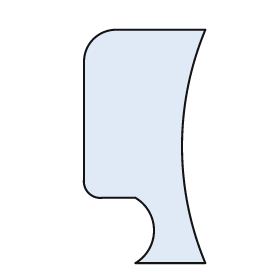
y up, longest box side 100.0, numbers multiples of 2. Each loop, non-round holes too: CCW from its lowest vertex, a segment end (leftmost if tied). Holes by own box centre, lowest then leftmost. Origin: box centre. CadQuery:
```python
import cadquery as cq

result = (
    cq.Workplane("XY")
    .moveTo(-4.0, -50.0)
    .lineTo(26.0, -50.0)
    .threePointArc((16.0, 0.0), (26.0, 50.0))
    .lineTo(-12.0, 50.0)
    .threePointArc((-22.0, 46.0), (-26.0, 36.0))
    .lineTo(-26.0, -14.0)
    .threePointArc((-24.0, -20.0), (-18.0, -22.0))
    .lineTo(-4.0, -22.0)
    .threePointArc((4.0, -36.0), (-4.0, -50.0))
    .close()
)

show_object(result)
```